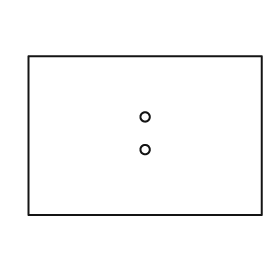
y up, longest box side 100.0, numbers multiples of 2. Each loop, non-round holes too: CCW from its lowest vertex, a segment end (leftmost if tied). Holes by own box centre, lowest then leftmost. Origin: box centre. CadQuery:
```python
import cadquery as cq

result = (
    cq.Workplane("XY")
    .moveTo(-50.0, -34.0)
    .lineTo(50.0, -34.0)
    .lineTo(50.0, 34.0)
    .lineTo(-50.0, 34.0)
    .close()
    .moveTo(0.0, -6.0)
    .circle(2.0)
    .moveTo(0.0, 8.0)
    .circle(2.0)
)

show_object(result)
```